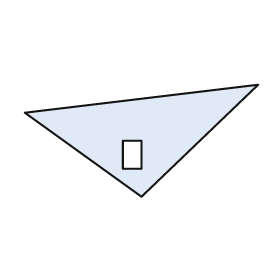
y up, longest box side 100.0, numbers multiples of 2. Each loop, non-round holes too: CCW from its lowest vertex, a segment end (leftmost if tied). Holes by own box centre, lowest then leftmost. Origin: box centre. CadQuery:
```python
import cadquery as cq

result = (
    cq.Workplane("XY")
    .moveTo(0.0, -24.0)
    .lineTo(50.0, 24.0)
    .lineTo(-50.0, 12.0)
    .close()
    .moveTo(-8.0, -12.0)
    .lineTo(0.0, -12.0)
    .lineTo(0.0, 0.0)
    .lineTo(-8.0, 0.0)
    .close()
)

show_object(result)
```